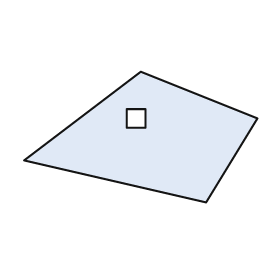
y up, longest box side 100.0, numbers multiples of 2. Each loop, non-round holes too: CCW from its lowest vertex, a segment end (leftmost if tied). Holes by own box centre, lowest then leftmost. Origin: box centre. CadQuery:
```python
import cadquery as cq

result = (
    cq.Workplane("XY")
    .moveTo(28.0, -28.0)
    .lineTo(50.0, 8.0)
    .lineTo(0.0, 28.0)
    .lineTo(-50.0, -10.0)
    .close()
    .moveTo(-6.0, 4.0)
    .lineTo(2.0, 4.0)
    .lineTo(2.0, 12.0)
    .lineTo(-6.0, 12.0)
    .close()
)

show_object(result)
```